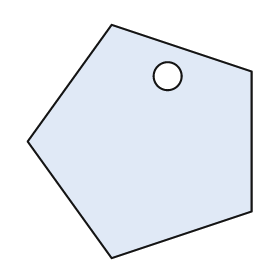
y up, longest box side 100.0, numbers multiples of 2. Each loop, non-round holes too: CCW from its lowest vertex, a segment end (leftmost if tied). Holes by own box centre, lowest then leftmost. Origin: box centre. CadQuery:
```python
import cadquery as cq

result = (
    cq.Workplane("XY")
    .moveTo(-12.0, -50.0)
    .lineTo(48.0, -30.0)
    .lineTo(48.0, 30.0)
    .lineTo(-12.0, 50.0)
    .lineTo(-48.0, 0.0)
    .close()
    .moveTo(12.0, 28.0)
    .circle(6.0)
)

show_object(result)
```